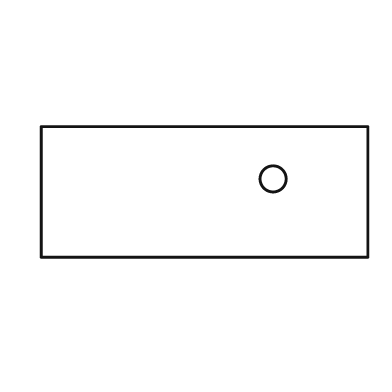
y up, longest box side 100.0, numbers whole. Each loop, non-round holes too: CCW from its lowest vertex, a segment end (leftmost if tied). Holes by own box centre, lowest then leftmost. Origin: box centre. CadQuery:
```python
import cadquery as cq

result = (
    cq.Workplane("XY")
    .moveTo(-50.0, -20.0)
    .lineTo(50.0, -20.0)
    .lineTo(50.0, 20.0)
    .lineTo(-50.0, 20.0)
    .close()
    .moveTo(21.0, 4.0)
    .circle(4.0)
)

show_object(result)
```